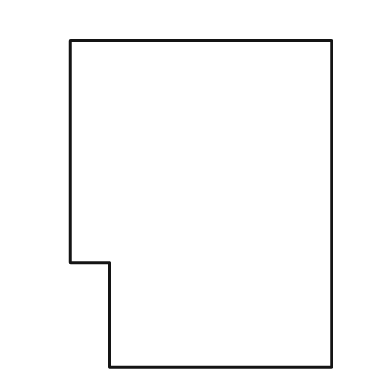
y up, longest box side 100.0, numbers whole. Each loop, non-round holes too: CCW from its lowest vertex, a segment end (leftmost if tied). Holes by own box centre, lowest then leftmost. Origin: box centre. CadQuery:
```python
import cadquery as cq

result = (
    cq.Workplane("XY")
    .moveTo(-28.0, -50.0)
    .lineTo(40.0, -50.0)
    .lineTo(40.0, 50.0)
    .lineTo(-40.0, 50.0)
    .lineTo(-40.0, -18.0)
    .lineTo(-28.0, -18.0)
    .close()
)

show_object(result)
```